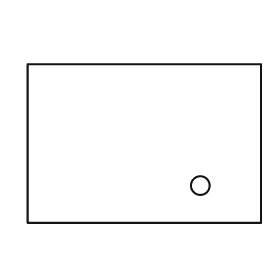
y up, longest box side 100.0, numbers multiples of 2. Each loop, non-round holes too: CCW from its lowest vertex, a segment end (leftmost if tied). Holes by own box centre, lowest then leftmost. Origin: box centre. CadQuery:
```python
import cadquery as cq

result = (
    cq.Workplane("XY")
    .moveTo(-50.0, -34.0)
    .lineTo(50.0, -34.0)
    .lineTo(50.0, 34.0)
    .lineTo(-50.0, 34.0)
    .close()
    .moveTo(24.0, -18.0)
    .circle(4.0)
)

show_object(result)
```